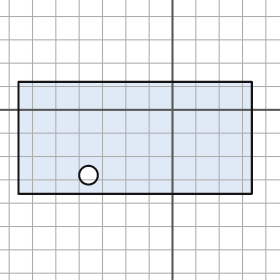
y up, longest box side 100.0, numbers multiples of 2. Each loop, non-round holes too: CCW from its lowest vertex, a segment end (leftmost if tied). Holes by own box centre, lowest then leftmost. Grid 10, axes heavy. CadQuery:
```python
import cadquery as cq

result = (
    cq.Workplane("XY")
    .moveTo(-66.0, -36.0)
    .lineTo(34.0, -36.0)
    .lineTo(34.0, 12.0)
    .lineTo(-66.0, 12.0)
    .close()
    .moveTo(-36.0, -28.0)
    .circle(4.0)
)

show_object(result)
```